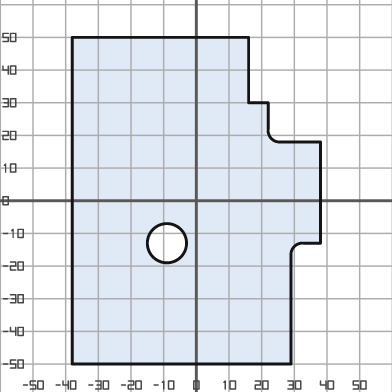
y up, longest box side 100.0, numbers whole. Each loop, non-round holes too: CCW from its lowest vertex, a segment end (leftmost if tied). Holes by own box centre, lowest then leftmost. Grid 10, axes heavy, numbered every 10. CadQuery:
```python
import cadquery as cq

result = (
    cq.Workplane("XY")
    .moveTo(-38.0, -50.0)
    .lineTo(29.0, -50.0)
    .lineTo(29.0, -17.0)
    .threePointArc((30.0, -14.0), (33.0, -13.0))
    .lineTo(38.0, -13.0)
    .lineTo(38.0, 18.0)
    .lineTo(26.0, 18.0)
    .threePointArc((23.0, 19.0), (22.0, 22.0))
    .lineTo(22.0, 30.0)
    .lineTo(16.0, 30.0)
    .lineTo(16.0, 50.0)
    .lineTo(-38.0, 50.0)
    .close()
    .moveTo(-9.0, -13.0)
    .circle(6.0)
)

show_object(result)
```